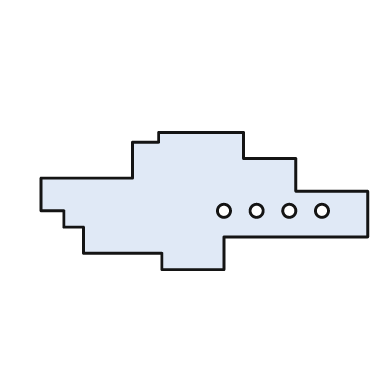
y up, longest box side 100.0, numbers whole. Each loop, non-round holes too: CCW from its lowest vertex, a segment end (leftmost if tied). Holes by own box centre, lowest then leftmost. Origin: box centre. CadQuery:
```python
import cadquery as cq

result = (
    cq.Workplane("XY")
    .moveTo(-13.0, -21.0)
    .lineTo(6.0, -21.0)
    .lineTo(6.0, -11.0)
    .lineTo(50.0, -11.0)
    .lineTo(50.0, 3.0)
    .lineTo(28.0, 3.0)
    .lineTo(28.0, 13.0)
    .lineTo(12.0, 13.0)
    .lineTo(12.0, 21.0)
    .lineTo(-14.0, 21.0)
    .lineTo(-14.0, 18.0)
    .lineTo(-22.0, 18.0)
    .lineTo(-22.0, 7.0)
    .lineTo(-50.0, 7.0)
    .lineTo(-50.0, -3.0)
    .lineTo(-43.0, -3.0)
    .lineTo(-43.0, -8.0)
    .lineTo(-37.0, -8.0)
    .lineTo(-37.0, -16.0)
    .lineTo(-13.0, -16.0)
    .close()
    .moveTo(6.0, -3.0)
    .circle(2.0)
    .moveTo(16.0, -3.0)
    .circle(2.0)
    .moveTo(26.0, -3.0)
    .circle(2.0)
    .moveTo(36.0, -3.0)
    .circle(2.0)
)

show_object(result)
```